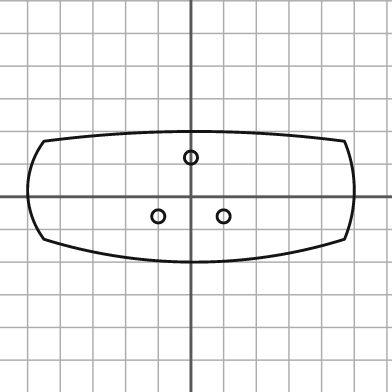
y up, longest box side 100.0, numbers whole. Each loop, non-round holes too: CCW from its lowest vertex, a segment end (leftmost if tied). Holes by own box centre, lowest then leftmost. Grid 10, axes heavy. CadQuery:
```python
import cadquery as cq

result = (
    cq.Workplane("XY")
    .moveTo(-45.0, -13.0)
    .threePointArc((1.0, -20.0), (47.0, -13.0))
    .threePointArc((50.0, 2.0), (47.0, 17.0))
    .threePointArc((1.0, 20.0), (-45.0, 17.0))
    .threePointArc((-50.0, 2.0), (-45.0, -13.0))
    .close()
    .moveTo(-10.0, -6.0)
    .circle(2.0)
    .moveTo(10.0, -6.0)
    .circle(2.0)
    .moveTo(0.0, 12.0)
    .circle(2.0)
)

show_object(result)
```